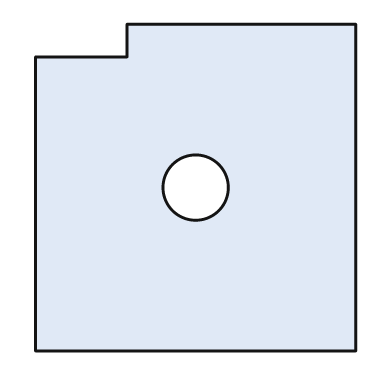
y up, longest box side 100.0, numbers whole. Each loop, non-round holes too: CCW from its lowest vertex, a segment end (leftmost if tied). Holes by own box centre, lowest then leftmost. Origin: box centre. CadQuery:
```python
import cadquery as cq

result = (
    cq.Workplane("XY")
    .moveTo(-49.0, -50.0)
    .lineTo(49.0, -50.0)
    .lineTo(49.0, 50.0)
    .lineTo(-21.0, 50.0)
    .lineTo(-21.0, 40.0)
    .lineTo(-49.0, 40.0)
    .close()
    .moveTo(0.0, 0.0)
    .circle(10.0)
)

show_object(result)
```